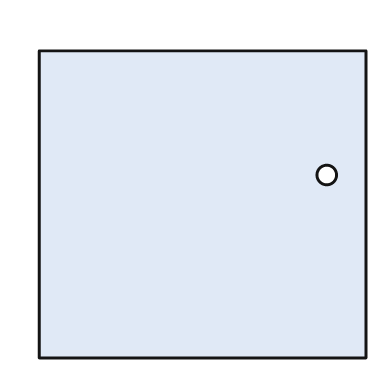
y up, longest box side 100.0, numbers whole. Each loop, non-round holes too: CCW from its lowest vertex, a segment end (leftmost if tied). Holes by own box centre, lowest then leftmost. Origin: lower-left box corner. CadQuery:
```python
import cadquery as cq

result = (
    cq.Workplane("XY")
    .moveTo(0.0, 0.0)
    .lineTo(100.0, 0.0)
    .lineTo(100.0, 94.0)
    .lineTo(0.0, 94.0)
    .close()
    .moveTo(88.0, 56.0)
    .circle(3.0)
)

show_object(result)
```